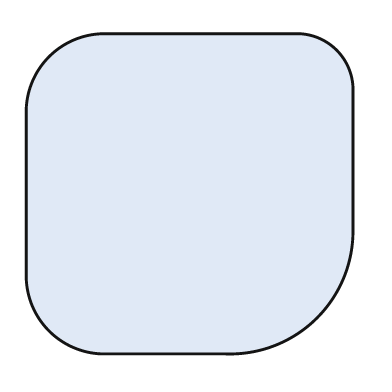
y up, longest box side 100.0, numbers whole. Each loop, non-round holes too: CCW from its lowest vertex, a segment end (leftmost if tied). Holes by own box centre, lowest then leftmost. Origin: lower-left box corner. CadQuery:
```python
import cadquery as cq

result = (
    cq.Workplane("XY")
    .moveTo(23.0, 0.0)
    .lineTo(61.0, 0.0)
    .threePointArc((89.0, 11.0), (100.0, 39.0))
    .lineTo(100.0, 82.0)
    .threePointArc((95.0, 93.0), (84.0, 98.0))
    .lineTo(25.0, 98.0)
    .threePointArc((7.0, 91.0), (0.0, 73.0))
    .lineTo(0.0, 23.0)
    .threePointArc((7.0, 7.0), (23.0, 0.0))
    .close()
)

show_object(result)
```